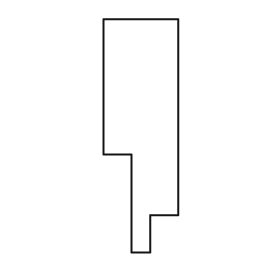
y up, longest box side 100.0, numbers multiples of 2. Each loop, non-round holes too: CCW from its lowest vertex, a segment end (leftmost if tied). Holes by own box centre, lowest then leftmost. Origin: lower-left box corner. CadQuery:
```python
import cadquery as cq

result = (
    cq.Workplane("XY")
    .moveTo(12.0, 0.0)
    .lineTo(20.0, 0.0)
    .lineTo(20.0, 16.0)
    .lineTo(32.0, 16.0)
    .lineTo(32.0, 100.0)
    .lineTo(0.0, 100.0)
    .lineTo(0.0, 42.0)
    .lineTo(12.0, 42.0)
    .close()
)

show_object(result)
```